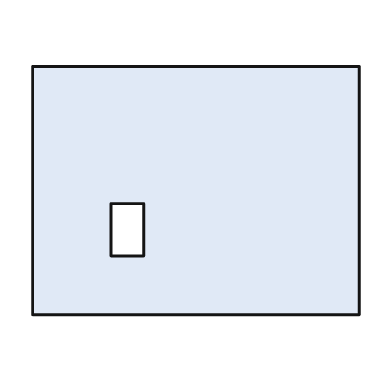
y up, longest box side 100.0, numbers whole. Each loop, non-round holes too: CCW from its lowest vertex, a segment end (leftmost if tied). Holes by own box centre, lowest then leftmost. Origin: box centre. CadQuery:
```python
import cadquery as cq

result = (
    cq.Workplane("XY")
    .moveTo(-50.0, -38.0)
    .lineTo(50.0, -38.0)
    .lineTo(50.0, 38.0)
    .lineTo(-50.0, 38.0)
    .close()
    .moveTo(-26.0, -20.0)
    .lineTo(-16.0, -20.0)
    .lineTo(-16.0, -4.0)
    .lineTo(-26.0, -4.0)
    .close()
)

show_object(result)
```